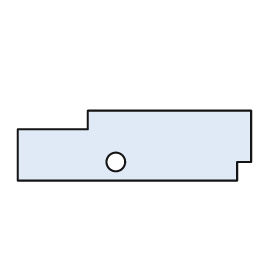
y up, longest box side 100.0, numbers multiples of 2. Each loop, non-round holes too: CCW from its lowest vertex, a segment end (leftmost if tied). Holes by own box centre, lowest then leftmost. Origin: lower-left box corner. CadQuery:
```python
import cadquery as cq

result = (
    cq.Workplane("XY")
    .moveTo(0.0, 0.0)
    .lineTo(94.0, 0.0)
    .lineTo(94.0, 8.0)
    .lineTo(100.0, 8.0)
    .lineTo(100.0, 30.0)
    .lineTo(30.0, 30.0)
    .lineTo(30.0, 22.0)
    .lineTo(0.0, 22.0)
    .close()
    .moveTo(42.0, 8.0)
    .circle(4.0)
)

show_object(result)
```